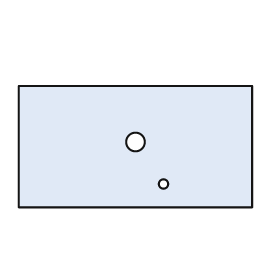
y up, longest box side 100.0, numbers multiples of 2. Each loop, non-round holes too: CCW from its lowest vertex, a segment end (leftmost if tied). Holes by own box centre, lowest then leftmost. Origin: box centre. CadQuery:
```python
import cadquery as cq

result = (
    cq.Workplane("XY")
    .moveTo(-50.0, -26.0)
    .lineTo(50.0, -26.0)
    .lineTo(50.0, 26.0)
    .lineTo(-50.0, 26.0)
    .close()
    .moveTo(12.0, -16.0)
    .circle(2.0)
    .moveTo(0.0, 2.0)
    .circle(4.0)
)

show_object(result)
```